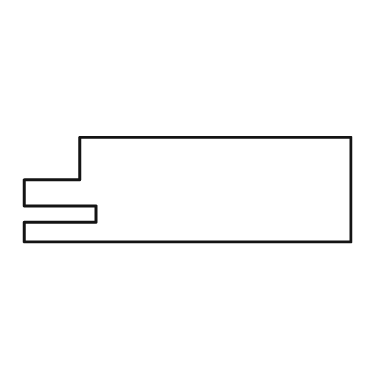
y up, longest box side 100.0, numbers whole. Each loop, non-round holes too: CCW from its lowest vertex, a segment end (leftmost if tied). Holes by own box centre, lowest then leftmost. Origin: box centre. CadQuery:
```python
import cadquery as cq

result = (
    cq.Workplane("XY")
    .moveTo(-50.0, -16.0)
    .lineTo(50.0, -16.0)
    .lineTo(50.0, 16.0)
    .lineTo(-33.0, 16.0)
    .lineTo(-33.0, 3.0)
    .lineTo(-50.0, 3.0)
    .lineTo(-50.0, -5.0)
    .lineTo(-28.0, -5.0)
    .lineTo(-28.0, -10.0)
    .lineTo(-50.0, -10.0)
    .close()
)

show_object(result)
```